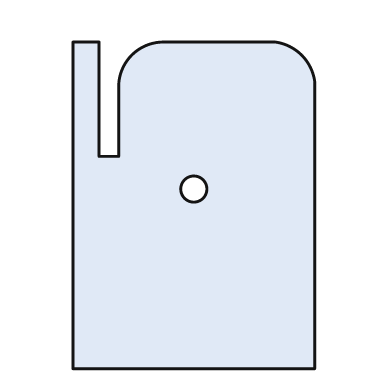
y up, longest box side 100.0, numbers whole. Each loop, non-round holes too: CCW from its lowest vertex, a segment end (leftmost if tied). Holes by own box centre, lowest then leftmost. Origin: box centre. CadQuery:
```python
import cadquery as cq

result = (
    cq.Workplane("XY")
    .moveTo(-37.0, -50.0)
    .lineTo(37.0, -50.0)
    .lineTo(37.0, 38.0)
    .threePointArc((33.0, 46.0), (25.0, 50.0))
    .lineTo(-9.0, 50.0)
    .threePointArc((-19.0, 46.0), (-23.0, 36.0))
    .lineTo(-23.0, 15.0)
    .lineTo(-29.0, 15.0)
    .lineTo(-29.0, 50.0)
    .lineTo(-37.0, 50.0)
    .close()
    .moveTo(0.0, 5.0)
    .circle(4.0)
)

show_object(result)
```